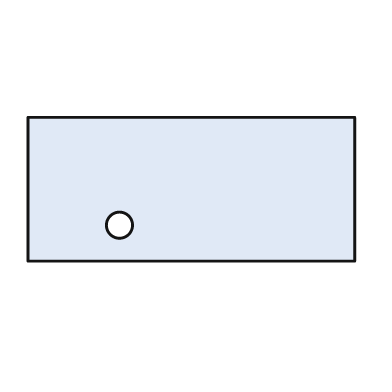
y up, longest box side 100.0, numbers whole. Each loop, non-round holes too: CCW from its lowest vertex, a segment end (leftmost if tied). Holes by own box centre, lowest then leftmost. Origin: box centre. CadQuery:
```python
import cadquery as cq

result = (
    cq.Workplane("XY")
    .moveTo(-50.0, -22.0)
    .lineTo(50.0, -22.0)
    .lineTo(50.0, 22.0)
    .lineTo(-50.0, 22.0)
    .close()
    .moveTo(-22.0, -11.0)
    .circle(4.0)
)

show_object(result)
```